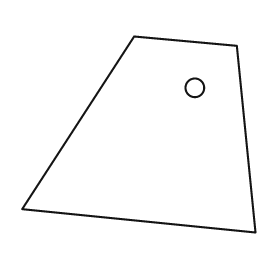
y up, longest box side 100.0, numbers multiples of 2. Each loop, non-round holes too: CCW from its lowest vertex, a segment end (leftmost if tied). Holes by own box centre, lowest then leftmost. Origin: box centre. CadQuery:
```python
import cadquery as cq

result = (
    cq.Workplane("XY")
    .moveTo(50.0, -42.0)
    .lineTo(42.0, 38.0)
    .lineTo(-2.0, 42.0)
    .lineTo(-50.0, -32.0)
    .close()
    .moveTo(24.0, 20.0)
    .circle(4.0)
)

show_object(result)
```